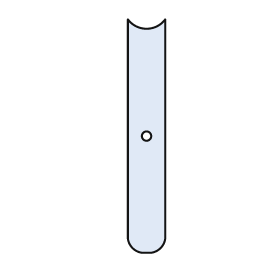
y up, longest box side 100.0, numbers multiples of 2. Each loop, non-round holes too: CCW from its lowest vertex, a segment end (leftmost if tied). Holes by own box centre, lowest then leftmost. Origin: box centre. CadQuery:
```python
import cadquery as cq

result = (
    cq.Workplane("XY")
    .moveTo(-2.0, -50.0)
    .lineTo(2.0, -50.0)
    .threePointArc((6.0, -48.0), (8.0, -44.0))
    .lineTo(8.0, 50.0)
    .threePointArc((0.0, 46.0), (-8.0, 50.0))
    .lineTo(-8.0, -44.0)
    .threePointArc((-6.0, -48.0), (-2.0, -50.0))
    .close()
    .moveTo(0.0, 0.0)
    .circle(2.0)
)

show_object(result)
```